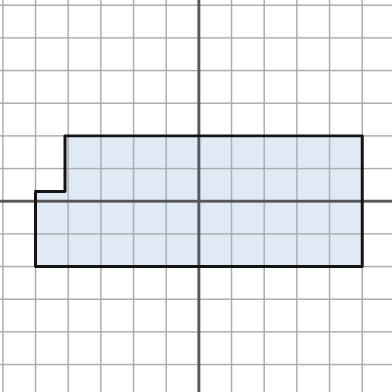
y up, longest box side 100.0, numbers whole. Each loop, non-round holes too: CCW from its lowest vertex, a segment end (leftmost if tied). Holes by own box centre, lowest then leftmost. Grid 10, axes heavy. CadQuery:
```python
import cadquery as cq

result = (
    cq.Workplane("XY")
    .moveTo(-50.0, -20.0)
    .lineTo(50.0, -20.0)
    .lineTo(50.0, 20.0)
    .lineTo(-41.0, 20.0)
    .lineTo(-41.0, 3.0)
    .lineTo(-50.0, 3.0)
    .close()
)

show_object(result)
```